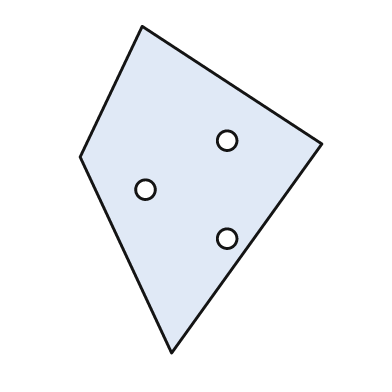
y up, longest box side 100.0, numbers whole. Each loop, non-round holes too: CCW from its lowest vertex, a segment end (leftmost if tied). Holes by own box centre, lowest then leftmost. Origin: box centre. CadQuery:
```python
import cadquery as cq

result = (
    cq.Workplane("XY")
    .moveTo(-9.0, -50.0)
    .lineTo(37.0, 14.0)
    .lineTo(-18.0, 50.0)
    .lineTo(-37.0, 10.0)
    .close()
    .moveTo(8.0, -15.0)
    .circle(3.0)
    .moveTo(-17.0, 0.0)
    .circle(3.0)
    .moveTo(8.0, 15.0)
    .circle(3.0)
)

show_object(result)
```